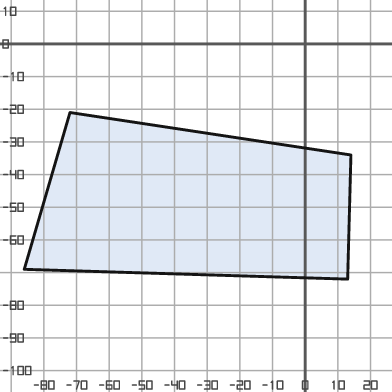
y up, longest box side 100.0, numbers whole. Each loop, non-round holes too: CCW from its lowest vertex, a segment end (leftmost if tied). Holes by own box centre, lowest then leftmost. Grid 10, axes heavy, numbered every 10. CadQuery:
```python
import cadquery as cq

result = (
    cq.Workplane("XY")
    .moveTo(13.0, -72.0)
    .lineTo(14.0, -34.0)
    .lineTo(-72.0, -21.0)
    .lineTo(-86.0, -69.0)
    .close()
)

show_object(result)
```